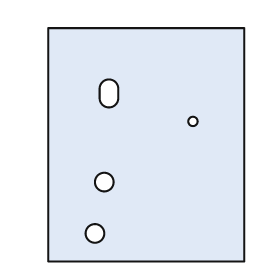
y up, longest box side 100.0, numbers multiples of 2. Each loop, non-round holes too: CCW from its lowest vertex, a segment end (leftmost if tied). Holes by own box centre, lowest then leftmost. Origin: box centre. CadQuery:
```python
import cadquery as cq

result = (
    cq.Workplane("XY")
    .moveTo(-42.0, -50.0)
    .lineTo(42.0, -50.0)
    .lineTo(42.0, 50.0)
    .lineTo(-42.0, 50.0)
    .close()
    .moveTo(-22.0, -38.0)
    .circle(4.0)
    .moveTo(-18.0, -16.0)
    .circle(4.0)
    .moveTo(20.0, 10.0)
    .circle(2.0)
    .moveTo(-20.0, 20.0)
    .threePointArc((-16.0, 16.0), (-12.0, 20.0))
    .lineTo(-12.0, 24.0)
    .threePointArc((-16.0, 28.0), (-20.0, 24.0))
    .close()
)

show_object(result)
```